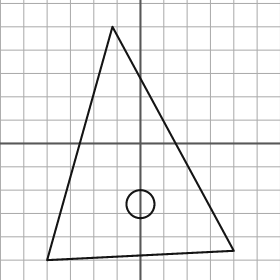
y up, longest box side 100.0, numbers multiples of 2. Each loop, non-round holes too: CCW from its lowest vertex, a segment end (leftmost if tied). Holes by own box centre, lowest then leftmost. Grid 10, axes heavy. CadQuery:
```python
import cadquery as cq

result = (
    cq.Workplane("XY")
    .moveTo(-40.0, -50.0)
    .lineTo(40.0, -46.0)
    .lineTo(-12.0, 50.0)
    .close()
    .moveTo(0.0, -26.0)
    .circle(6.0)
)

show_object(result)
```